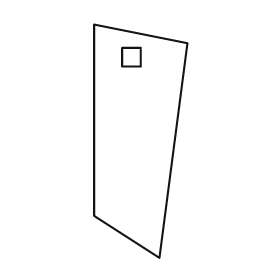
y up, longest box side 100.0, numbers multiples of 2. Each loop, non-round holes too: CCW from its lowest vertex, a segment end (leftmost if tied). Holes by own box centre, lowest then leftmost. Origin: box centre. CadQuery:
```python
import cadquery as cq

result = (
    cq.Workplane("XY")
    .moveTo(8.0, -50.0)
    .lineTo(20.0, 42.0)
    .lineTo(-20.0, 50.0)
    .lineTo(-20.0, -32.0)
    .close()
    .moveTo(-8.0, 32.0)
    .lineTo(0.0, 32.0)
    .lineTo(0.0, 40.0)
    .lineTo(-8.0, 40.0)
    .close()
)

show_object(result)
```